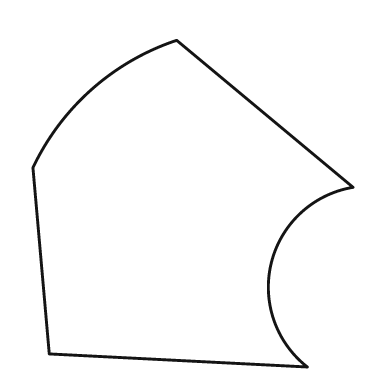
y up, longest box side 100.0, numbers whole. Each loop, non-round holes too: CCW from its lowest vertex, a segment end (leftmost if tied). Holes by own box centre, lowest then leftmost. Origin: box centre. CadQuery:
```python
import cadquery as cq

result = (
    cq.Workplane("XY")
    .moveTo(35.0, -50.0)
    .threePointArc((24.0, -18.0), (49.0, 5.0))
    .lineTo(-5.0, 50.0)
    .threePointArc((-31.0, 35.0), (-49.0, 11.0))
    .lineTo(-44.0, -46.0)
    .close()
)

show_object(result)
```